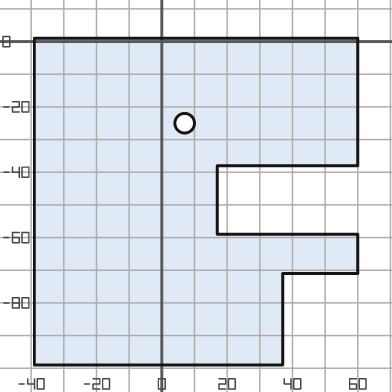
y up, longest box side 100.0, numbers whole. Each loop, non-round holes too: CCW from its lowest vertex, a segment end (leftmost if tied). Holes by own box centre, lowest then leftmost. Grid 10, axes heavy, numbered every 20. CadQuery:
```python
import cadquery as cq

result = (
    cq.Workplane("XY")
    .moveTo(-39.0, -99.0)
    .lineTo(37.0, -99.0)
    .lineTo(37.0, -71.0)
    .lineTo(60.0, -71.0)
    .lineTo(60.0, -59.0)
    .lineTo(17.0, -59.0)
    .lineTo(17.0, -38.0)
    .lineTo(60.0, -38.0)
    .lineTo(60.0, 1.0)
    .lineTo(-39.0, 1.0)
    .close()
    .moveTo(7.0, -25.0)
    .circle(3.0)
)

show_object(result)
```